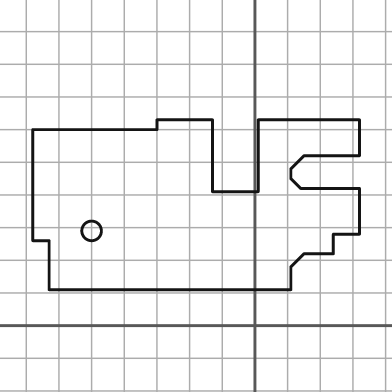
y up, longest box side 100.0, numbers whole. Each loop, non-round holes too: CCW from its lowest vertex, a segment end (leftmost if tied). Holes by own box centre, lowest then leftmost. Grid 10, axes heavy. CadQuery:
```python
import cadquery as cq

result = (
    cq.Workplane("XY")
    .moveTo(-63.0, 11.0)
    .lineTo(11.0, 11.0)
    .lineTo(11.0, 18.0)
    .lineTo(15.0, 22.0)
    .lineTo(24.0, 22.0)
    .lineTo(24.0, 28.0)
    .lineTo(32.0, 28.0)
    .lineTo(32.0, 42.0)
    .lineTo(14.0, 42.0)
    .lineTo(11.0, 45.0)
    .lineTo(11.0, 48.0)
    .lineTo(15.0, 52.0)
    .lineTo(32.0, 52.0)
    .lineTo(32.0, 63.0)
    .lineTo(1.0, 63.0)
    .lineTo(1.0, 41.0)
    .lineTo(-13.0, 41.0)
    .lineTo(-13.0, 63.0)
    .lineTo(-30.0, 63.0)
    .lineTo(-30.0, 60.0)
    .lineTo(-68.0, 60.0)
    .lineTo(-68.0, 26.0)
    .lineTo(-63.0, 26.0)
    .close()
    .moveTo(-50.0, 29.0)
    .circle(3.0)
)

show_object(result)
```